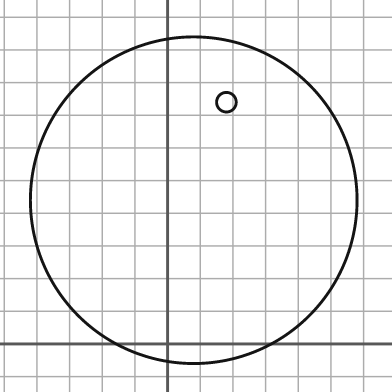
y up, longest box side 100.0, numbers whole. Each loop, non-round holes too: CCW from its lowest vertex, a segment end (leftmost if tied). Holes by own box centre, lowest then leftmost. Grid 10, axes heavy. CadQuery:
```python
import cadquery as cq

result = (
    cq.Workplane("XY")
    .moveTo(8.0, 44.0)
    .circle(50.0)
    .moveTo(18.0, 74.0)
    .circle(3.0)
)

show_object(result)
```